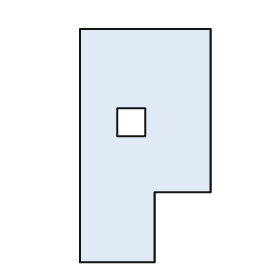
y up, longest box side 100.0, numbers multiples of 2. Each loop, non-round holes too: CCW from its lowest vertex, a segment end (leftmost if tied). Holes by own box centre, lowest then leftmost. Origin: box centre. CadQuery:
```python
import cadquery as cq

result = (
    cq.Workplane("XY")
    .moveTo(-28.0, -50.0)
    .lineTo(4.0, -50.0)
    .lineTo(4.0, -20.0)
    .lineTo(28.0, -20.0)
    .lineTo(28.0, 50.0)
    .lineTo(-28.0, 50.0)
    .close()
    .moveTo(-12.0, 4.0)
    .lineTo(0.0, 4.0)
    .lineTo(0.0, 16.0)
    .lineTo(-12.0, 16.0)
    .close()
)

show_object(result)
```